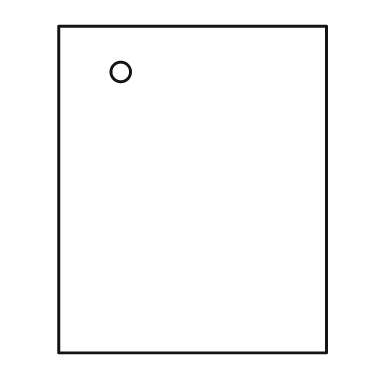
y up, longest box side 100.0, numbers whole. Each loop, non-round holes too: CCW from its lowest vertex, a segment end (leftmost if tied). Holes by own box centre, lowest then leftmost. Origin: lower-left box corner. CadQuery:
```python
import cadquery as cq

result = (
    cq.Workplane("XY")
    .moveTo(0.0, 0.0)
    .lineTo(82.0, 0.0)
    .lineTo(82.0, 100.0)
    .lineTo(0.0, 100.0)
    .close()
    .moveTo(19.0, 86.0)
    .circle(3.0)
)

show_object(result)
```